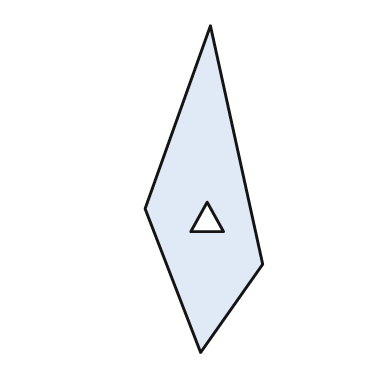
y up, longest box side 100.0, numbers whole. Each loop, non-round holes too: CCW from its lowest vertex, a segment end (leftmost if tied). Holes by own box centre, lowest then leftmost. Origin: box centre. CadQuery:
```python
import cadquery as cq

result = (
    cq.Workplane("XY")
    .moveTo(-1.0, -50.0)
    .lineTo(18.0, -23.0)
    .lineTo(2.0, 50.0)
    .lineTo(-18.0, -6.0)
    .close()
    .moveTo(-4.0, -13.0)
    .lineTo(6.0, -13.0)
    .lineTo(1.0, -4.0)
    .close()
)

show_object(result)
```